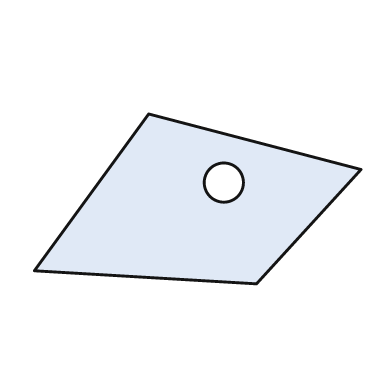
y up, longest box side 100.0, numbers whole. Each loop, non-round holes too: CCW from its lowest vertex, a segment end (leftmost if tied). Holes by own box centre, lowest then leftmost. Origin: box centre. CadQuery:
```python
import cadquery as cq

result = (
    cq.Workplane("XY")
    .moveTo(18.0, -26.0)
    .lineTo(50.0, 9.0)
    .lineTo(-15.0, 26.0)
    .lineTo(-50.0, -22.0)
    .close()
    .moveTo(8.0, 5.0)
    .circle(6.0)
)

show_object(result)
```